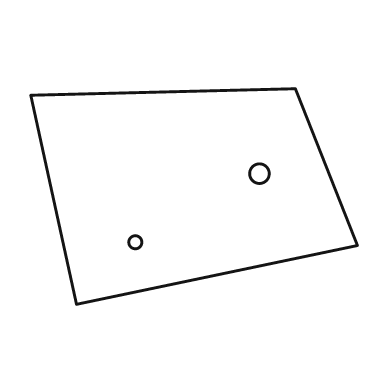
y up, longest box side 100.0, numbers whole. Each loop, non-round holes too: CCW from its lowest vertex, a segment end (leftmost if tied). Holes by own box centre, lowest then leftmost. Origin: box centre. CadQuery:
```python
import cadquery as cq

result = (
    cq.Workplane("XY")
    .moveTo(-36.0, -33.0)
    .lineTo(50.0, -15.0)
    .lineTo(31.0, 33.0)
    .lineTo(-50.0, 31.0)
    .close()
    .moveTo(-18.0, -14.0)
    .circle(2.0)
    .moveTo(20.0, 7.0)
    .circle(3.0)
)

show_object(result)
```